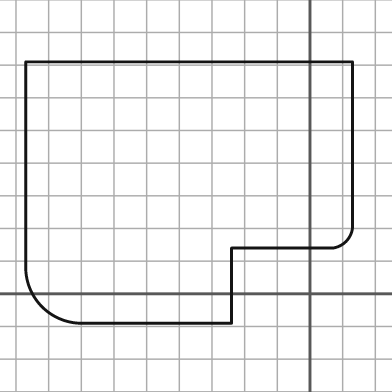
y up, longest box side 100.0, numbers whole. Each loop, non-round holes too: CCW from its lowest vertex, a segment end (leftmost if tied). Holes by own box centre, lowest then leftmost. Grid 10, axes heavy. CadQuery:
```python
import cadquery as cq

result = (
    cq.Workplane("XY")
    .moveTo(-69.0, -9.0)
    .lineTo(-24.0, -9.0)
    .lineTo(-24.0, 14.0)
    .lineTo(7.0, 14.0)
    .threePointArc((11.0, 16.0), (13.0, 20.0))
    .lineTo(13.0, 71.0)
    .lineTo(-87.0, 71.0)
    .lineTo(-87.0, 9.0)
    .threePointArc((-82.0, -4.0), (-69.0, -9.0))
    .close()
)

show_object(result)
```